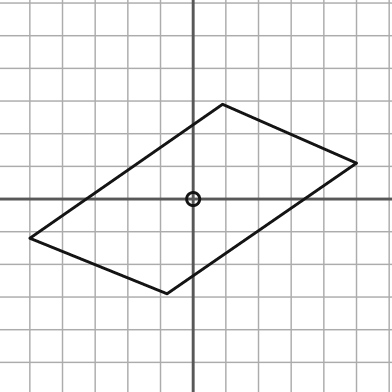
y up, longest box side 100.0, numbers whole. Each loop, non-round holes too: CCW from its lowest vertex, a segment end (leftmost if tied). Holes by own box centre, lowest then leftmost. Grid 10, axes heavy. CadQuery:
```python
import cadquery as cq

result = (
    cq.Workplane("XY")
    .moveTo(-8.0, -29.0)
    .lineTo(50.0, 11.0)
    .lineTo(9.0, 29.0)
    .lineTo(-50.0, -12.0)
    .close()
    .moveTo(0.0, 0.0)
    .circle(2.0)
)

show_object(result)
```